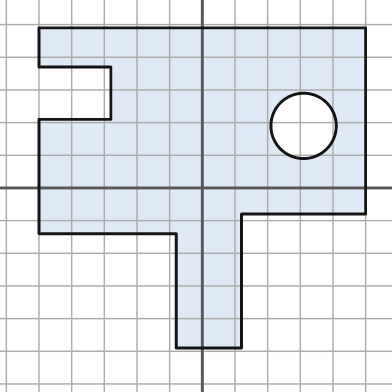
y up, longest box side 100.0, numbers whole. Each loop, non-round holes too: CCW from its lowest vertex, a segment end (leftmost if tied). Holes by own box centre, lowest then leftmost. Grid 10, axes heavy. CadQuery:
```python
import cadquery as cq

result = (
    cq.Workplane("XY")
    .moveTo(-8.0, -49.0)
    .lineTo(12.0, -49.0)
    .lineTo(12.0, -8.0)
    .lineTo(50.0, -8.0)
    .lineTo(50.0, 49.0)
    .lineTo(-50.0, 49.0)
    .lineTo(-50.0, 37.0)
    .lineTo(-28.0, 37.0)
    .lineTo(-28.0, 21.0)
    .lineTo(-50.0, 21.0)
    .lineTo(-50.0, -14.0)
    .lineTo(-8.0, -14.0)
    .close()
    .moveTo(31.0, 19.0)
    .circle(10.0)
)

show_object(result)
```